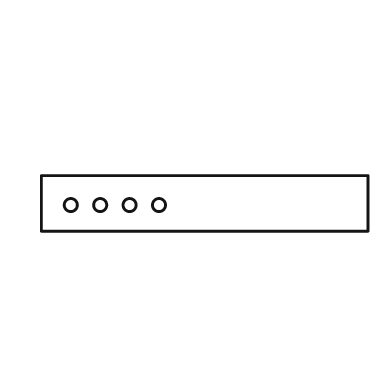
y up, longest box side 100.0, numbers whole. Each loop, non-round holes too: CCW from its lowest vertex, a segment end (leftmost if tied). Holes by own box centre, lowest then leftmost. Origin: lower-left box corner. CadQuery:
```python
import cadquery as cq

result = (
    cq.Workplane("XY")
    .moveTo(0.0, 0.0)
    .lineTo(100.0, 0.0)
    .lineTo(100.0, 17.0)
    .lineTo(0.0, 17.0)
    .close()
    .moveTo(9.0, 8.0)
    .circle(2.0)
    .moveTo(18.0, 8.0)
    .circle(2.0)
    .moveTo(27.0, 8.0)
    .circle(2.0)
    .moveTo(36.0, 8.0)
    .circle(2.0)
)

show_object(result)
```